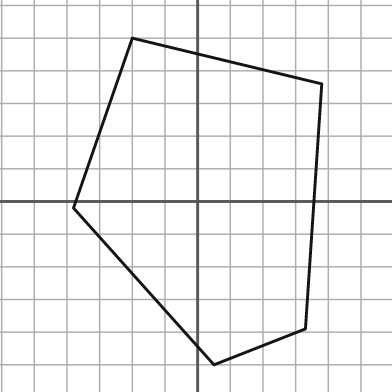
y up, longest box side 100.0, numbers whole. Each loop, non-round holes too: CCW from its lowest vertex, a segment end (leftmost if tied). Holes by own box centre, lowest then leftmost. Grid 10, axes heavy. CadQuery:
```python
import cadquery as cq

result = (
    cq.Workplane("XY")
    .moveTo(5.0, -50.0)
    .lineTo(33.0, -39.0)
    .lineTo(38.0, 36.0)
    .lineTo(-20.0, 50.0)
    .lineTo(-38.0, -2.0)
    .close()
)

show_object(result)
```